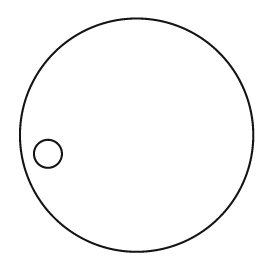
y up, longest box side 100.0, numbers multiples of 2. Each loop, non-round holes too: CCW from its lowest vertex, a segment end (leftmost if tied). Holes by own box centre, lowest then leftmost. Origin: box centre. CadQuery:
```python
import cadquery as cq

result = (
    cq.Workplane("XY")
    .moveTo(0.0, 0.0)
    .circle(50.0)
    .moveTo(-38.0, -8.0)
    .circle(6.0)
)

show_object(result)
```